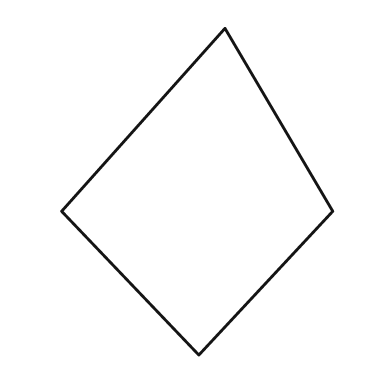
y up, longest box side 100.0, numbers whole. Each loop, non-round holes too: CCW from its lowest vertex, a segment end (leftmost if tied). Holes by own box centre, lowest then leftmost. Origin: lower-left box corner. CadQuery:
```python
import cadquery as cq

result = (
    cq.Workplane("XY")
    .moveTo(42.0, 0.0)
    .lineTo(83.0, 44.0)
    .lineTo(50.0, 100.0)
    .lineTo(0.0, 44.0)
    .close()
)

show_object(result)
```